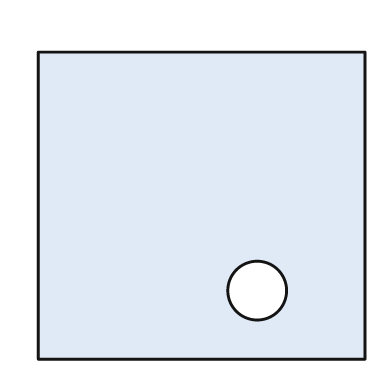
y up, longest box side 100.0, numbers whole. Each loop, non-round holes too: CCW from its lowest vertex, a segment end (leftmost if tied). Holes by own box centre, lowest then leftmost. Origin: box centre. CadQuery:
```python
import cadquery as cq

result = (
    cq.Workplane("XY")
    .moveTo(-50.0, -47.0)
    .lineTo(50.0, -47.0)
    .lineTo(50.0, 47.0)
    .lineTo(-50.0, 47.0)
    .close()
    .moveTo(17.0, -26.0)
    .circle(9.0)
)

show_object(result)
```